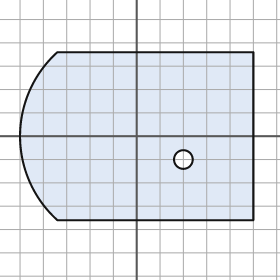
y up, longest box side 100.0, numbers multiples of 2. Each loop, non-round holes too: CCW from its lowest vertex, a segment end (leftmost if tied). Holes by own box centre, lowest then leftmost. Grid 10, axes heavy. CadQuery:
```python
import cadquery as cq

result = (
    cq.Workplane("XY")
    .moveTo(-34.0, -36.0)
    .lineTo(50.0, -36.0)
    .lineTo(50.0, 36.0)
    .lineTo(-34.0, 36.0)
    .threePointArc((-50.0, 0.0), (-34.0, -36.0))
    .close()
    .moveTo(20.0, -10.0)
    .circle(4.0)
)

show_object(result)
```